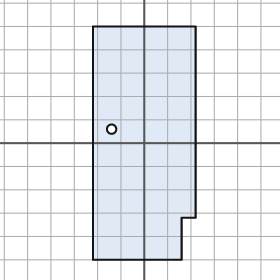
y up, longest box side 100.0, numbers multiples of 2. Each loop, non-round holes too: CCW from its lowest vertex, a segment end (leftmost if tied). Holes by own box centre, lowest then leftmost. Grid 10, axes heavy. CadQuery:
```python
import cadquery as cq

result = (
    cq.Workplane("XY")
    .moveTo(-22.0, -50.0)
    .lineTo(16.0, -50.0)
    .lineTo(16.0, -32.0)
    .lineTo(22.0, -32.0)
    .lineTo(22.0, 50.0)
    .lineTo(-22.0, 50.0)
    .close()
    .moveTo(-14.0, 6.0)
    .circle(2.0)
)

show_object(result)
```